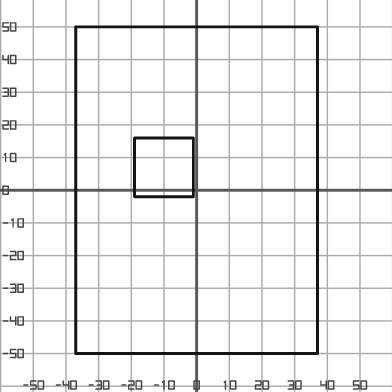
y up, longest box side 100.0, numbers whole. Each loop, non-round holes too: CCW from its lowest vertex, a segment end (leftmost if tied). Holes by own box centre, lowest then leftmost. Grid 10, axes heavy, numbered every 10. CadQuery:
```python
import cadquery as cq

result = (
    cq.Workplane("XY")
    .moveTo(-37.0, -50.0)
    .lineTo(37.0, -50.0)
    .lineTo(37.0, 50.0)
    .lineTo(-37.0, 50.0)
    .close()
    .moveTo(-19.0, -2.0)
    .lineTo(-1.0, -2.0)
    .lineTo(-1.0, 16.0)
    .lineTo(-19.0, 16.0)
    .close()
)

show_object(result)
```